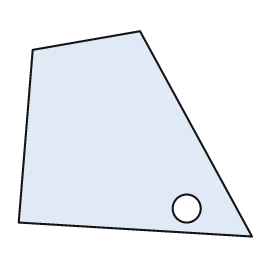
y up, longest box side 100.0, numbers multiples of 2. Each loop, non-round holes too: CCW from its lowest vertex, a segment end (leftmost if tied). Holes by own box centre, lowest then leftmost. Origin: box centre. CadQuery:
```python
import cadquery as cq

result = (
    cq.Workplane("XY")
    .moveTo(50.0, -44.0)
    .lineTo(2.0, 44.0)
    .lineTo(-44.0, 36.0)
    .lineTo(-50.0, -38.0)
    .close()
    .moveTo(22.0, -32.0)
    .circle(6.0)
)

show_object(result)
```